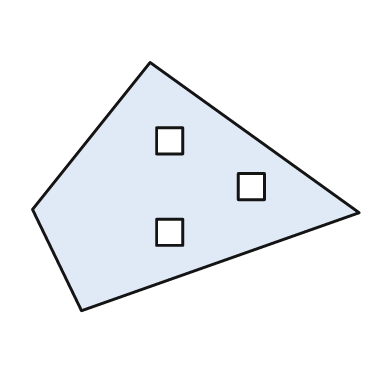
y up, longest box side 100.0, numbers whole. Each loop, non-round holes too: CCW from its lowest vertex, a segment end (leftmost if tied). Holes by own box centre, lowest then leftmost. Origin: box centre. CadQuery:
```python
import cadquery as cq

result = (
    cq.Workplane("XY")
    .moveTo(-35.0, -38.0)
    .lineTo(50.0, -8.0)
    .lineTo(-14.0, 38.0)
    .lineTo(-50.0, -7.0)
    .close()
    .moveTo(-12.0, -18.0)
    .lineTo(-4.0, -18.0)
    .lineTo(-4.0, -10.0)
    .lineTo(-12.0, -10.0)
    .close()
    .moveTo(13.0, -4.0)
    .lineTo(21.0, -4.0)
    .lineTo(21.0, 4.0)
    .lineTo(13.0, 4.0)
    .close()
    .moveTo(-12.0, 10.0)
    .lineTo(-4.0, 10.0)
    .lineTo(-4.0, 18.0)
    .lineTo(-12.0, 18.0)
    .close()
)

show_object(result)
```